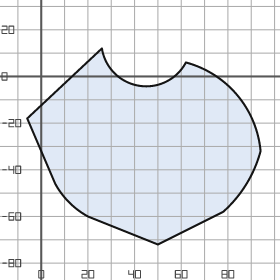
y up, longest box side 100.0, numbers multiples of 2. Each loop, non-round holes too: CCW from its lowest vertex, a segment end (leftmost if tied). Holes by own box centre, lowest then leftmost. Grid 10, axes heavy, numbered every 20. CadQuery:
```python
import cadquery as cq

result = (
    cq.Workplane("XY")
    .moveTo(50.0, -72.0)
    .lineTo(78.0, -58.0)
    .threePointArc((88.0, -46.0), (94.0, -32.0))
    .threePointArc((84.0, -8.0), (62.0, 6.0))
    .threePointArc((42.0, -4.0), (26.0, 12.0))
    .lineTo(-6.0, -18.0)
    .lineTo(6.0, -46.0)
    .threePointArc((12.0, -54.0), (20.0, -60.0))
    .close()
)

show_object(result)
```